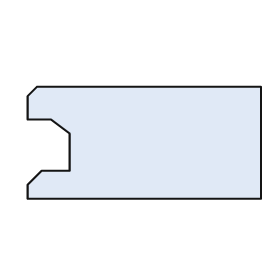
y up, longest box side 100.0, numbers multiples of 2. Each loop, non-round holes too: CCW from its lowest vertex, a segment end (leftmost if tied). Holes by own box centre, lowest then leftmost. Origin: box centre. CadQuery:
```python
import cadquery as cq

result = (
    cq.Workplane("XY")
    .moveTo(-50.0, -24.0)
    .lineTo(50.0, -24.0)
    .lineTo(50.0, 24.0)
    .lineTo(-46.0, 24.0)
    .lineTo(-50.0, 20.0)
    .lineTo(-50.0, 10.0)
    .lineTo(-40.0, 10.0)
    .lineTo(-32.0, 4.0)
    .lineTo(-32.0, -12.0)
    .lineTo(-44.0, -12.0)
    .lineTo(-50.0, -18.0)
    .close()
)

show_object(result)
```